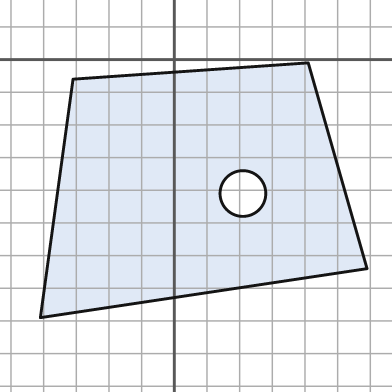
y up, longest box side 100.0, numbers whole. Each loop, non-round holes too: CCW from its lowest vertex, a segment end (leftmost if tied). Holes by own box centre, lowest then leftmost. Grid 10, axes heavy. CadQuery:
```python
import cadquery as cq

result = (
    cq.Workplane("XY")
    .moveTo(-41.0, -79.0)
    .lineTo(59.0, -64.0)
    .lineTo(41.0, -1.0)
    .lineTo(-31.0, -6.0)
    .close()
    .moveTo(21.0, -41.0)
    .circle(7.0)
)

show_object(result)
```